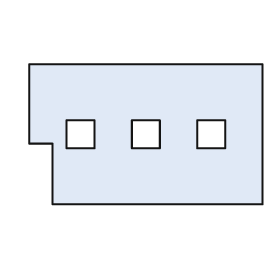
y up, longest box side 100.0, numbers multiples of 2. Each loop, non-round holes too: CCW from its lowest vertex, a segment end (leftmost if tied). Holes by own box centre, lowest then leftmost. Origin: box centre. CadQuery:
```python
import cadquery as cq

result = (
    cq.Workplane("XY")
    .moveTo(-40.0, -30.0)
    .lineTo(50.0, -30.0)
    .lineTo(50.0, 30.0)
    .lineTo(-50.0, 30.0)
    .lineTo(-50.0, -4.0)
    .lineTo(-40.0, -4.0)
    .close()
    .moveTo(-34.0, -6.0)
    .lineTo(-22.0, -6.0)
    .lineTo(-22.0, 6.0)
    .lineTo(-34.0, 6.0)
    .close()
    .moveTo(-6.0, -6.0)
    .lineTo(6.0, -6.0)
    .lineTo(6.0, 6.0)
    .lineTo(-6.0, 6.0)
    .close()
    .moveTo(22.0, -6.0)
    .lineTo(34.0, -6.0)
    .lineTo(34.0, 6.0)
    .lineTo(22.0, 6.0)
    .close()
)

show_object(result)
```